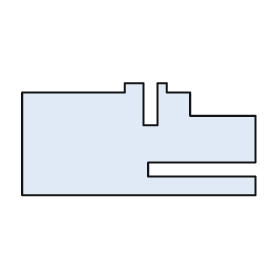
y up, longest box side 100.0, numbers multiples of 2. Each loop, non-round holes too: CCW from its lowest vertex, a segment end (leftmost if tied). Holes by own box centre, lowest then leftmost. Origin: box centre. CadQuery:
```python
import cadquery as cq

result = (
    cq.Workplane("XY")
    .moveTo(-50.0, -24.0)
    .lineTo(50.0, -24.0)
    .lineTo(50.0, -16.0)
    .lineTo(4.0, -16.0)
    .lineTo(4.0, -10.0)
    .lineTo(50.0, -10.0)
    .lineTo(50.0, 10.0)
    .lineTo(22.0, 10.0)
    .lineTo(22.0, 20.0)
    .lineTo(12.0, 20.0)
    .lineTo(12.0, 24.0)
    .lineTo(8.0, 24.0)
    .lineTo(8.0, 6.0)
    .lineTo(2.0, 6.0)
    .lineTo(2.0, 24.0)
    .lineTo(-6.0, 24.0)
    .lineTo(-6.0, 20.0)
    .lineTo(-50.0, 20.0)
    .close()
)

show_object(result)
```